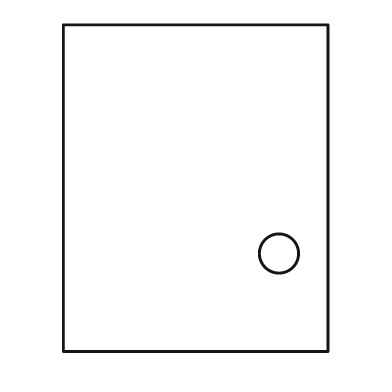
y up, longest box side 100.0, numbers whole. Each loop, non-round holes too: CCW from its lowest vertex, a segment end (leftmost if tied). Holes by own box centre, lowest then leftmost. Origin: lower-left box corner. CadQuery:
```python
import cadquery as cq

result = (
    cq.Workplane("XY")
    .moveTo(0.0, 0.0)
    .lineTo(81.0, 0.0)
    .lineTo(81.0, 100.0)
    .lineTo(0.0, 100.0)
    .close()
    .moveTo(66.0, 30.0)
    .circle(6.0)
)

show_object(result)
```